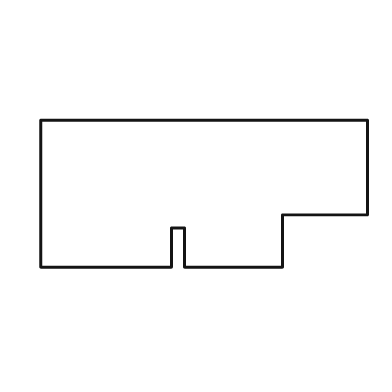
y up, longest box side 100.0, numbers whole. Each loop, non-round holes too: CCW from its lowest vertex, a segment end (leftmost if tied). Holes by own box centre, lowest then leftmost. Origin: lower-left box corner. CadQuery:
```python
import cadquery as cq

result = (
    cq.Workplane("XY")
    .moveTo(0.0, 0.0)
    .lineTo(40.0, 0.0)
    .lineTo(40.0, 12.0)
    .lineTo(44.0, 12.0)
    .lineTo(44.0, 0.0)
    .lineTo(74.0, 0.0)
    .lineTo(74.0, 16.0)
    .lineTo(100.0, 16.0)
    .lineTo(100.0, 45.0)
    .lineTo(0.0, 45.0)
    .close()
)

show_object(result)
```